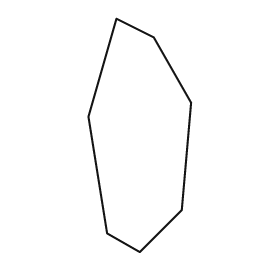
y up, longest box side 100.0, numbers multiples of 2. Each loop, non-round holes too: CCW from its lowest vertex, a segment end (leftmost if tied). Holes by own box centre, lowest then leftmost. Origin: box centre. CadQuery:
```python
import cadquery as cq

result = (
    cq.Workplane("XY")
    .moveTo(0.0, -50.0)
    .lineTo(18.0, -32.0)
    .lineTo(22.0, 14.0)
    .lineTo(6.0, 42.0)
    .lineTo(-10.0, 50.0)
    .lineTo(-22.0, 8.0)
    .lineTo(-14.0, -42.0)
    .close()
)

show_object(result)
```